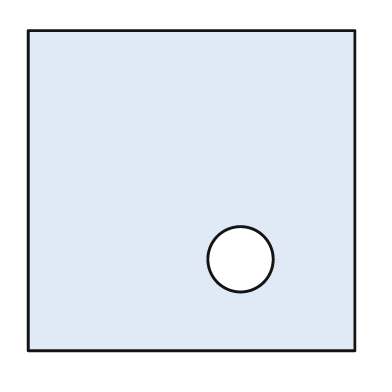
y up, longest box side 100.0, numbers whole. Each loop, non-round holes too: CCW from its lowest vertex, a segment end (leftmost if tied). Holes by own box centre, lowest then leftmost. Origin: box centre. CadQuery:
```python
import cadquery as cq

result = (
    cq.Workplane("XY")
    .moveTo(-50.0, -49.0)
    .lineTo(50.0, -49.0)
    .lineTo(50.0, 49.0)
    .lineTo(-50.0, 49.0)
    .close()
    .moveTo(15.0, -21.0)
    .circle(10.0)
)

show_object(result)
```